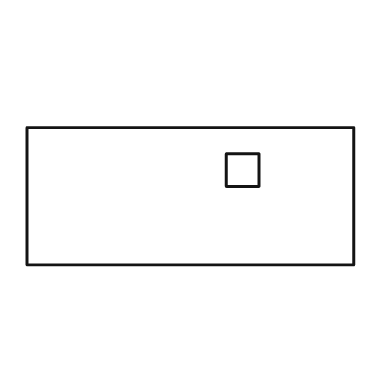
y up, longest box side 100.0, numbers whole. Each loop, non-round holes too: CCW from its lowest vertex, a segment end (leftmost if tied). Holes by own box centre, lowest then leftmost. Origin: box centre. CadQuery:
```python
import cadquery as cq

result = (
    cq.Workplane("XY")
    .moveTo(-50.0, -21.0)
    .lineTo(50.0, -21.0)
    .lineTo(50.0, 21.0)
    .lineTo(-50.0, 21.0)
    .close()
    .moveTo(11.0, 3.0)
    .lineTo(21.0, 3.0)
    .lineTo(21.0, 13.0)
    .lineTo(11.0, 13.0)
    .close()
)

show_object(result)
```